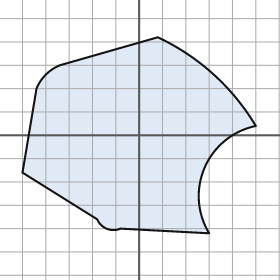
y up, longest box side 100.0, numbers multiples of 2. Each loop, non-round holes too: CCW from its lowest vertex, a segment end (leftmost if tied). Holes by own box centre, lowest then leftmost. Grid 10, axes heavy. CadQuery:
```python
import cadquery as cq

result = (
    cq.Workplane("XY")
    .moveTo(30.0, -42.0)
    .threePointArc((28.0, -14.0), (50.0, 4.0))
    .threePointArc((32.0, 26.0), (8.0, 42.0))
    .lineTo(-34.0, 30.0)
    .threePointArc((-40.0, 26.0), (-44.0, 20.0))
    .lineTo(-50.0, -16.0)
    .lineTo(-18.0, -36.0)
    .threePointArc((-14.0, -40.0), (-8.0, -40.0))
    .close()
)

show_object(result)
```